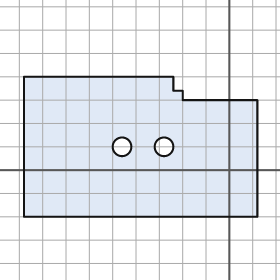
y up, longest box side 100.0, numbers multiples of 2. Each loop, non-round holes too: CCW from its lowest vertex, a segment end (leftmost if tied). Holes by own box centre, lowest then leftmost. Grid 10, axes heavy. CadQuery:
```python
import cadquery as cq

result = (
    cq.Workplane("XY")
    .moveTo(-88.0, -20.0)
    .lineTo(12.0, -20.0)
    .lineTo(12.0, 30.0)
    .lineTo(-20.0, 30.0)
    .lineTo(-20.0, 34.0)
    .lineTo(-24.0, 34.0)
    .lineTo(-24.0, 40.0)
    .lineTo(-88.0, 40.0)
    .close()
    .moveTo(-46.0, 10.0)
    .circle(4.0)
    .moveTo(-28.0, 10.0)
    .circle(4.0)
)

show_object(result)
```